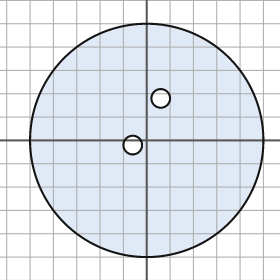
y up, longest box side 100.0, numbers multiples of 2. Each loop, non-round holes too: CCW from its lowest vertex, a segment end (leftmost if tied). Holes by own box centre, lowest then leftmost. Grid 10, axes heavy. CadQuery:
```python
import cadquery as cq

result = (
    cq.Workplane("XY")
    .moveTo(0.0, 0.0)
    .circle(50.0)
    .moveTo(-6.0, -2.0)
    .circle(4.0)
    .moveTo(6.0, 18.0)
    .circle(4.0)
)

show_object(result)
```